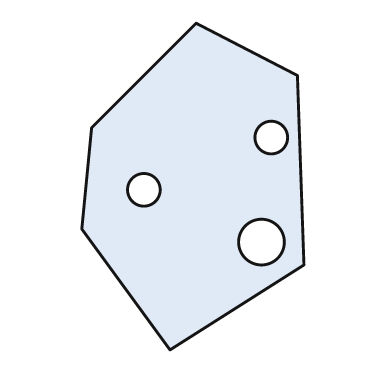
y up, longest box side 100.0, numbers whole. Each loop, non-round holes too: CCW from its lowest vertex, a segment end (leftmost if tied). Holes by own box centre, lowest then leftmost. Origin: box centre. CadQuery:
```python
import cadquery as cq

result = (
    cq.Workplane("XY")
    .moveTo(-7.0, -50.0)
    .lineTo(34.0, -24.0)
    .lineTo(32.0, 34.0)
    .lineTo(1.0, 50.0)
    .lineTo(-31.0, 18.0)
    .lineTo(-34.0, -13.0)
    .close()
    .moveTo(21.0, -17.0)
    .circle(7.0)
    .moveTo(-15.0, -1.0)
    .circle(5.0)
    .moveTo(24.0, 15.0)
    .circle(5.0)
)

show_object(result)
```